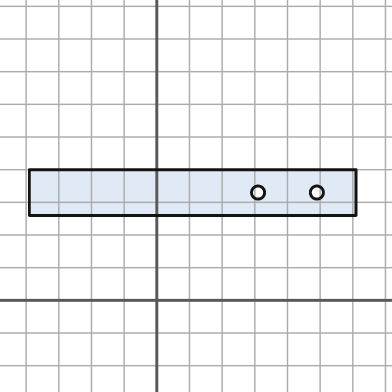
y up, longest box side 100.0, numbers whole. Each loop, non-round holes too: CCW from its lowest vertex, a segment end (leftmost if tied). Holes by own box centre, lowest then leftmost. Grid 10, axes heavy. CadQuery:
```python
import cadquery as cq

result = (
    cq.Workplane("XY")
    .moveTo(-39.0, 26.0)
    .lineTo(61.0, 26.0)
    .lineTo(61.0, 40.0)
    .lineTo(-39.0, 40.0)
    .close()
    .moveTo(31.0, 33.0)
    .circle(2.0)
    .moveTo(49.0, 33.0)
    .circle(2.0)
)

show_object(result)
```